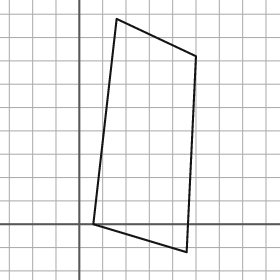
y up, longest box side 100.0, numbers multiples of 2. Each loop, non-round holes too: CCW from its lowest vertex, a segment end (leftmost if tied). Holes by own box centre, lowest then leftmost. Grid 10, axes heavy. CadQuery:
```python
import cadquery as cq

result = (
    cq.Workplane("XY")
    .moveTo(46.0, -12.0)
    .lineTo(50.0, 72.0)
    .lineTo(16.0, 88.0)
    .lineTo(6.0, 0.0)
    .close()
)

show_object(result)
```